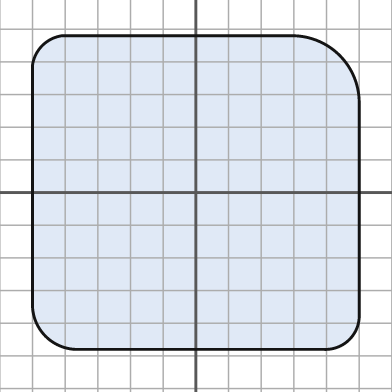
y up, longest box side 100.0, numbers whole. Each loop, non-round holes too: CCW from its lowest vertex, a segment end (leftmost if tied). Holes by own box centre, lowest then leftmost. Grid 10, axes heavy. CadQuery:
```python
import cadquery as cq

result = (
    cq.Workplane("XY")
    .moveTo(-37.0, -48.0)
    .lineTo(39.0, -48.0)
    .threePointArc((47.0, -45.0), (50.0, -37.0))
    .lineTo(50.0, 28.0)
    .threePointArc((44.0, 42.0), (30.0, 48.0))
    .lineTo(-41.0, 48.0)
    .threePointArc((-47.0, 45.0), (-50.0, 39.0))
    .lineTo(-50.0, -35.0)
    .threePointArc((-46.0, -44.0), (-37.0, -48.0))
    .close()
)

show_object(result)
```